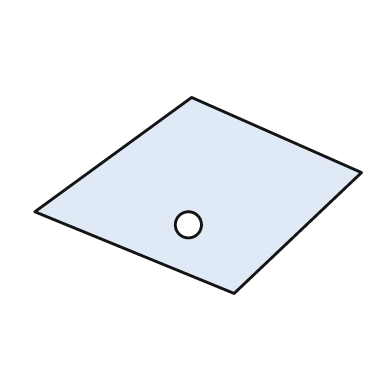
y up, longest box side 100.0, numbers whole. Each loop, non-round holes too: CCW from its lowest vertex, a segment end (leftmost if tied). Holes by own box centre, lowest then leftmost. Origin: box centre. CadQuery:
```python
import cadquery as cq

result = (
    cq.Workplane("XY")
    .moveTo(11.0, -30.0)
    .lineTo(50.0, 7.0)
    .lineTo(-2.0, 30.0)
    .lineTo(-50.0, -5.0)
    .close()
    .moveTo(-3.0, -9.0)
    .circle(4.0)
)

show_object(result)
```